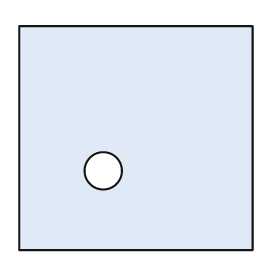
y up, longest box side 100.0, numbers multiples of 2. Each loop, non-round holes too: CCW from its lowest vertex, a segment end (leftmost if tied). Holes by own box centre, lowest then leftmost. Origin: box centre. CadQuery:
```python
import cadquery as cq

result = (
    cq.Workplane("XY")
    .moveTo(-50.0, -48.0)
    .lineTo(50.0, -48.0)
    .lineTo(50.0, 48.0)
    .lineTo(-50.0, 48.0)
    .close()
    .moveTo(-14.0, -14.0)
    .circle(8.0)
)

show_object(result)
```